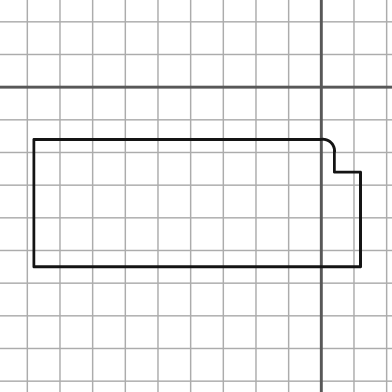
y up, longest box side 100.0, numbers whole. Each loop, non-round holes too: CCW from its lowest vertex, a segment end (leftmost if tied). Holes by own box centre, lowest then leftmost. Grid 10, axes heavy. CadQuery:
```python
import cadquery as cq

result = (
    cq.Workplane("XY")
    .moveTo(-88.0, -55.0)
    .lineTo(12.0, -55.0)
    .lineTo(12.0, -26.0)
    .lineTo(4.0, -26.0)
    .lineTo(4.0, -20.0)
    .threePointArc((3.0, -17.0), (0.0, -16.0))
    .lineTo(-88.0, -16.0)
    .close()
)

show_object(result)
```